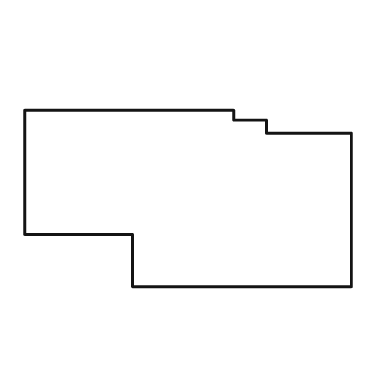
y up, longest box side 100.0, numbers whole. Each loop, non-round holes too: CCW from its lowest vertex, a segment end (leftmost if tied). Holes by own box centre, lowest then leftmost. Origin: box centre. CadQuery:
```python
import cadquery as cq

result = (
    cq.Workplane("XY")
    .moveTo(-17.0, -27.0)
    .lineTo(50.0, -27.0)
    .lineTo(50.0, 20.0)
    .lineTo(24.0, 20.0)
    .lineTo(24.0, 24.0)
    .lineTo(14.0, 24.0)
    .lineTo(14.0, 27.0)
    .lineTo(-50.0, 27.0)
    .lineTo(-50.0, -11.0)
    .lineTo(-17.0, -11.0)
    .close()
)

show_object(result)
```